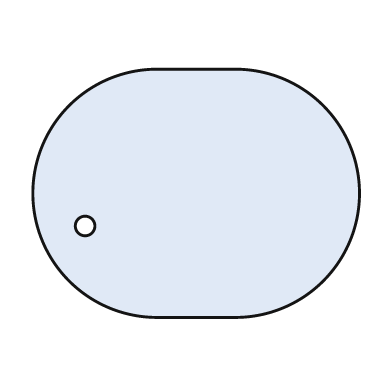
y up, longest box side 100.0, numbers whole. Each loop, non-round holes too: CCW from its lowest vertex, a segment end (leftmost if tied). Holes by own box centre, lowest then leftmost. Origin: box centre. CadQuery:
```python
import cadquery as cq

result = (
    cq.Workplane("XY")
    .moveTo(-12.0, -38.0)
    .lineTo(12.0, -38.0)
    .threePointArc((50.0, 0.0), (12.0, 38.0))
    .lineTo(-12.0, 38.0)
    .threePointArc((-50.0, 0.0), (-12.0, -38.0))
    .close()
    .moveTo(-34.0, -10.0)
    .circle(3.0)
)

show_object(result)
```